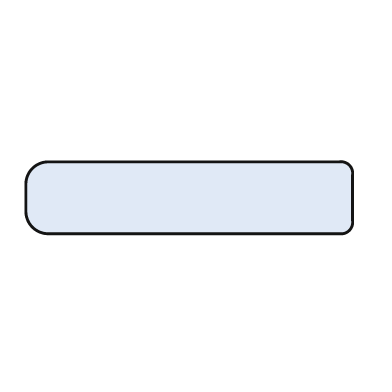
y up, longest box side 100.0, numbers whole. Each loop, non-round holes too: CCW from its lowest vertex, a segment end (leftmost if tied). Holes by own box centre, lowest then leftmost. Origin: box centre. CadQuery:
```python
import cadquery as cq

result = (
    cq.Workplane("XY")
    .moveTo(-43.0, -11.0)
    .lineTo(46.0, -11.0)
    .threePointArc((49.0, -10.0), (50.0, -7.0))
    .lineTo(50.0, 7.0)
    .threePointArc((49.0, 10.0), (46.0, 11.0))
    .lineTo(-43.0, 11.0)
    .threePointArc((-48.0, 9.0), (-50.0, 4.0))
    .lineTo(-50.0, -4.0)
    .threePointArc((-48.0, -9.0), (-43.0, -11.0))
    .close()
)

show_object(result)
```